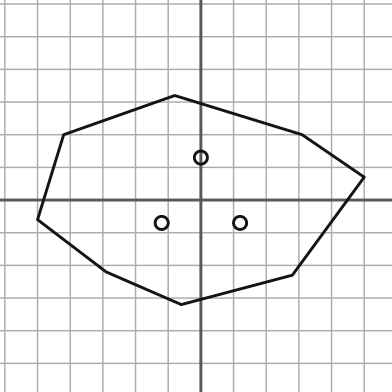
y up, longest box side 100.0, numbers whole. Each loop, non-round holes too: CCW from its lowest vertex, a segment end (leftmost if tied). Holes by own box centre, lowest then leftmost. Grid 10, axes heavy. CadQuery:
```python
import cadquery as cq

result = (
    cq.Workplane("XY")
    .moveTo(-6.0, -32.0)
    .lineTo(28.0, -23.0)
    .lineTo(50.0, 7.0)
    .lineTo(31.0, 20.0)
    .lineTo(-8.0, 32.0)
    .lineTo(-42.0, 20.0)
    .lineTo(-50.0, -6.0)
    .lineTo(-29.0, -22.0)
    .close()
    .moveTo(-12.0, -7.0)
    .circle(2.0)
    .moveTo(12.0, -7.0)
    .circle(2.0)
    .moveTo(0.0, 13.0)
    .circle(2.0)
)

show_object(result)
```